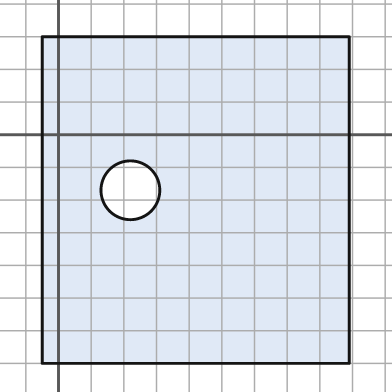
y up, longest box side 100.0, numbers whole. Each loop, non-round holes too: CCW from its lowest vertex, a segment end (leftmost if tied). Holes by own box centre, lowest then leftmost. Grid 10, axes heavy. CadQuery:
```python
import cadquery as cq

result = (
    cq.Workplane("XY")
    .moveTo(-5.0, -70.0)
    .lineTo(89.0, -70.0)
    .lineTo(89.0, 30.0)
    .lineTo(-5.0, 30.0)
    .close()
    .moveTo(22.0, -17.0)
    .circle(9.0)
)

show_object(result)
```